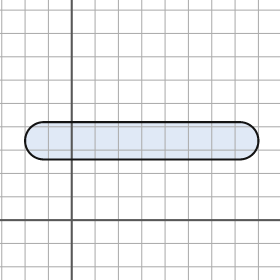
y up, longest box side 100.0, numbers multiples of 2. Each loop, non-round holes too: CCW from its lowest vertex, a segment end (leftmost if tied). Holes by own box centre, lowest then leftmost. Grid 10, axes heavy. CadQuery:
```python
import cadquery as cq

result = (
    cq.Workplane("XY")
    .moveTo(-12.0, 26.0)
    .lineTo(72.0, 26.0)
    .threePointArc((80.0, 34.0), (72.0, 42.0))
    .lineTo(-12.0, 42.0)
    .threePointArc((-20.0, 34.0), (-12.0, 26.0))
    .close()
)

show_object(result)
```